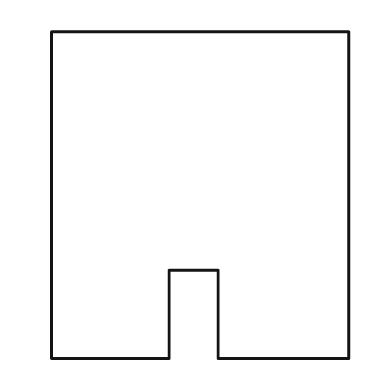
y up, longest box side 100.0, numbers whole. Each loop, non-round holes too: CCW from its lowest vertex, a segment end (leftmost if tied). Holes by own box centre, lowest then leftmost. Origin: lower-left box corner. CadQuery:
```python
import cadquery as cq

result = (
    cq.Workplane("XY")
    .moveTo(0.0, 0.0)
    .lineTo(36.0, 0.0)
    .lineTo(36.0, 27.0)
    .lineTo(51.0, 27.0)
    .lineTo(51.0, 0.0)
    .lineTo(91.0, 0.0)
    .lineTo(91.0, 100.0)
    .lineTo(0.0, 100.0)
    .close()
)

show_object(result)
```